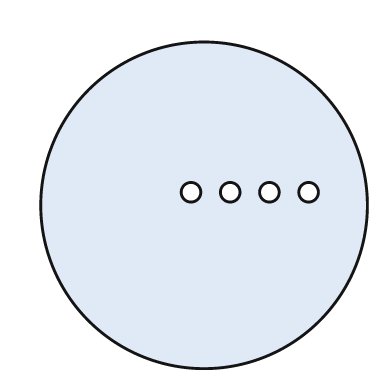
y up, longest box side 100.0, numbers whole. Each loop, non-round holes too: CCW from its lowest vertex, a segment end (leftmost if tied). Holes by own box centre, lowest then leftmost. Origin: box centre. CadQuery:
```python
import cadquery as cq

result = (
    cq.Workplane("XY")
    .moveTo(0.0, 0.0)
    .circle(50.0)
    .moveTo(-4.0, 4.0)
    .circle(3.0)
    .moveTo(8.0, 4.0)
    .circle(3.0)
    .moveTo(20.0, 4.0)
    .circle(3.0)
    .moveTo(32.0, 4.0)
    .circle(3.0)
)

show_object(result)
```